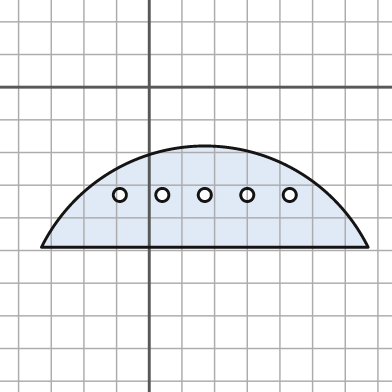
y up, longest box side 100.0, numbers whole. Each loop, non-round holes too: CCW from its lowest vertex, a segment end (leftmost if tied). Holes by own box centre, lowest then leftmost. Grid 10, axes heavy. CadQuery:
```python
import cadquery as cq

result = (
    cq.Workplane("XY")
    .moveTo(-33.0, -49.0)
    .lineTo(67.0, -49.0)
    .threePointArc((17.0, -18.0), (-33.0, -49.0))
    .close()
    .moveTo(-9.0, -33.0)
    .circle(2.0)
    .moveTo(4.0, -33.0)
    .circle(2.0)
    .moveTo(17.0, -33.0)
    .circle(2.0)
    .moveTo(30.0, -33.0)
    .circle(2.0)
    .moveTo(43.0, -33.0)
    .circle(2.0)
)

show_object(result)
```